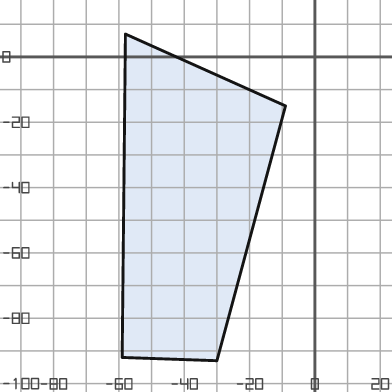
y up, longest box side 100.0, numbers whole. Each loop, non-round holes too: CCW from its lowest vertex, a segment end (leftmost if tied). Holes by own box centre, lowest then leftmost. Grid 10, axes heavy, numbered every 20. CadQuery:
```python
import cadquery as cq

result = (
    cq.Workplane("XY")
    .moveTo(-30.0, -93.0)
    .lineTo(-9.0, -15.0)
    .lineTo(-58.0, 7.0)
    .lineTo(-59.0, -92.0)
    .close()
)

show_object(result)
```